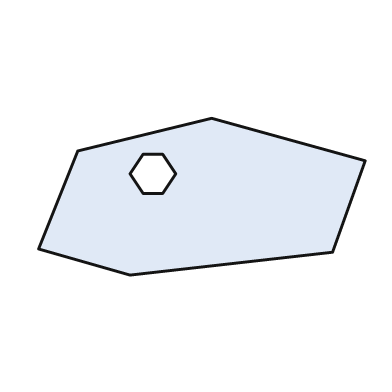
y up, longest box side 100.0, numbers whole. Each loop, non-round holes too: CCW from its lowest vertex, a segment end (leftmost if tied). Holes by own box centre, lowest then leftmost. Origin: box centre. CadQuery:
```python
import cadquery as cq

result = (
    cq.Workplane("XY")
    .moveTo(-22.0, -24.0)
    .lineTo(40.0, -17.0)
    .lineTo(50.0, 11.0)
    .lineTo(3.0, 24.0)
    .lineTo(-38.0, 14.0)
    .lineTo(-50.0, -16.0)
    .close()
    .moveTo(-18.0, 1.0)
    .lineTo(-12.0, 1.0)
    .lineTo(-8.0, 7.0)
    .lineTo(-12.0, 13.0)
    .lineTo(-18.0, 13.0)
    .lineTo(-22.0, 7.0)
    .close()
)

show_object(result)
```